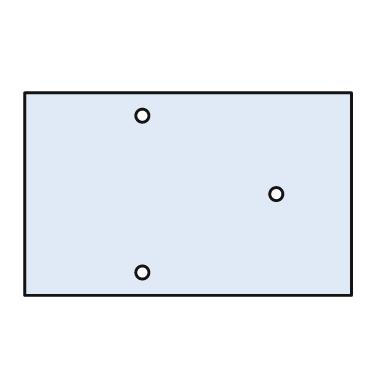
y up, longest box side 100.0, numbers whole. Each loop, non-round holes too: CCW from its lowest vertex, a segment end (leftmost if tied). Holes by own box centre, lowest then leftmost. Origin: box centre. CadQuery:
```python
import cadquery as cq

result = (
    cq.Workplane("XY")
    .moveTo(-50.0, -31.0)
    .lineTo(50.0, -31.0)
    .lineTo(50.0, 31.0)
    .lineTo(-50.0, 31.0)
    .close()
    .moveTo(-14.0, -24.0)
    .circle(2.0)
    .moveTo(27.0, 0.0)
    .circle(2.0)
    .moveTo(-14.0, 24.0)
    .circle(2.0)
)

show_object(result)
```